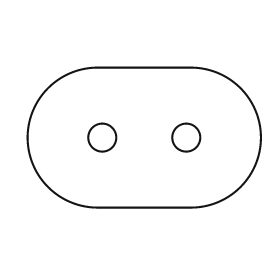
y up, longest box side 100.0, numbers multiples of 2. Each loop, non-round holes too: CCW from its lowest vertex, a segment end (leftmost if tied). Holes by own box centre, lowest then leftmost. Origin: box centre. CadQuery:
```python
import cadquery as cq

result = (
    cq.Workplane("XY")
    .moveTo(-20.0, -30.0)
    .lineTo(20.0, -30.0)
    .threePointArc((50.0, 0.0), (20.0, 30.0))
    .lineTo(-20.0, 30.0)
    .threePointArc((-50.0, 0.0), (-20.0, -30.0))
    .close()
    .moveTo(-18.0, 0.0)
    .circle(6.0)
    .moveTo(18.0, 0.0)
    .circle(6.0)
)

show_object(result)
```